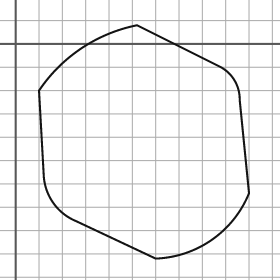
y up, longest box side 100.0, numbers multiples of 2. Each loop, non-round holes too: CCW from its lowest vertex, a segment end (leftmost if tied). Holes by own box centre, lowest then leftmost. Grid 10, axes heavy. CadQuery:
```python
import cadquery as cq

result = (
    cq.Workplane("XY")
    .moveTo(60.0, -92.0)
    .threePointArc((84.0, -84.0), (100.0, -64.0))
    .lineTo(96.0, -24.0)
    .threePointArc((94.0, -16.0), (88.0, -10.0))
    .lineTo(52.0, 8.0)
    .threePointArc((28.0, -2.0), (10.0, -20.0))
    .lineTo(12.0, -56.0)
    .threePointArc((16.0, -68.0), (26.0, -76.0))
    .close()
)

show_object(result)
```